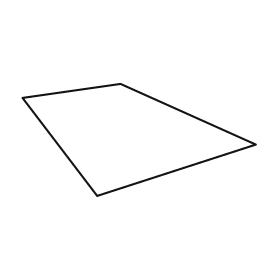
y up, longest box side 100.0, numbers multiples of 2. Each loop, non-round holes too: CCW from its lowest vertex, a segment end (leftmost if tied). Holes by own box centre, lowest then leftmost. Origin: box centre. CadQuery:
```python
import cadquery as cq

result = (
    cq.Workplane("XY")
    .moveTo(-18.0, -24.0)
    .lineTo(50.0, -2.0)
    .lineTo(-8.0, 24.0)
    .lineTo(-50.0, 18.0)
    .close()
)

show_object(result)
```